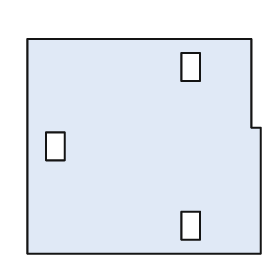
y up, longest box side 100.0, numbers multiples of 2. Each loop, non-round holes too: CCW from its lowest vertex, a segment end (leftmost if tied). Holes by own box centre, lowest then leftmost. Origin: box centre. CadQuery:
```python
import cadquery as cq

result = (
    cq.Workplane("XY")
    .moveTo(-50.0, -46.0)
    .lineTo(50.0, -46.0)
    .lineTo(50.0, 8.0)
    .lineTo(46.0, 8.0)
    .lineTo(46.0, 46.0)
    .lineTo(-50.0, 46.0)
    .close()
    .moveTo(16.0, -40.0)
    .lineTo(24.0, -40.0)
    .lineTo(24.0, -28.0)
    .lineTo(16.0, -28.0)
    .close()
    .moveTo(-42.0, -6.0)
    .lineTo(-34.0, -6.0)
    .lineTo(-34.0, 6.0)
    .lineTo(-42.0, 6.0)
    .close()
    .moveTo(16.0, 28.0)
    .lineTo(24.0, 28.0)
    .lineTo(24.0, 40.0)
    .lineTo(16.0, 40.0)
    .close()
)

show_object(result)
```